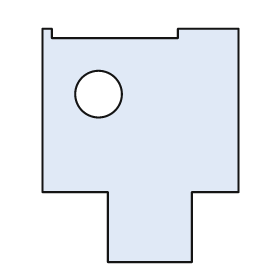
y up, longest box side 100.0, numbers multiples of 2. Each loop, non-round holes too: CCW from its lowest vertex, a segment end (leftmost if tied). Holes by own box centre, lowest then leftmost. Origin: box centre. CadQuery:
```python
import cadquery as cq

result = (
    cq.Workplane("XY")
    .moveTo(-14.0, -50.0)
    .lineTo(22.0, -50.0)
    .lineTo(22.0, -20.0)
    .lineTo(42.0, -20.0)
    .lineTo(42.0, 50.0)
    .lineTo(16.0, 50.0)
    .lineTo(16.0, 46.0)
    .lineTo(-38.0, 46.0)
    .lineTo(-38.0, 50.0)
    .lineTo(-42.0, 50.0)
    .lineTo(-42.0, -20.0)
    .lineTo(-14.0, -20.0)
    .close()
    .moveTo(-18.0, 22.0)
    .circle(10.0)
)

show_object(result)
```